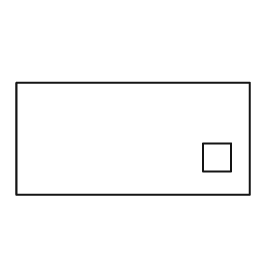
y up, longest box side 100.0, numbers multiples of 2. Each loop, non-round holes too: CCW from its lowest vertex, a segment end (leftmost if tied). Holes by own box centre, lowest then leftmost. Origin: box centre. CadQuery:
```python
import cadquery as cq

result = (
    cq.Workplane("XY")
    .moveTo(-50.0, -24.0)
    .lineTo(50.0, -24.0)
    .lineTo(50.0, 24.0)
    .lineTo(-50.0, 24.0)
    .close()
    .moveTo(30.0, -14.0)
    .lineTo(42.0, -14.0)
    .lineTo(42.0, -2.0)
    .lineTo(30.0, -2.0)
    .close()
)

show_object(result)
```